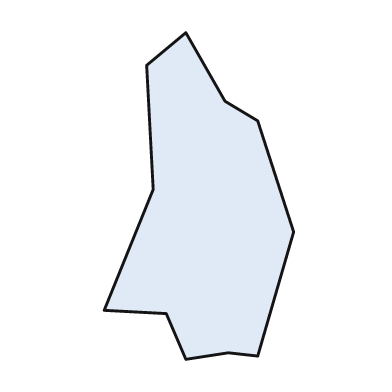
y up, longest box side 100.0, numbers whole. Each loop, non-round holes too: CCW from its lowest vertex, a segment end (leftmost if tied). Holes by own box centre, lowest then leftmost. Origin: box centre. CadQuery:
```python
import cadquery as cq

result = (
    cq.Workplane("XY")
    .moveTo(-4.0, -50.0)
    .lineTo(9.0, -48.0)
    .lineTo(18.0, -49.0)
    .lineTo(29.0, -11.0)
    .lineTo(18.0, 23.0)
    .lineTo(8.0, 29.0)
    .lineTo(-4.0, 50.0)
    .lineTo(-16.0, 40.0)
    .lineTo(-14.0, 2.0)
    .lineTo(-29.0, -35.0)
    .lineTo(-10.0, -36.0)
    .close()
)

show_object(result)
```